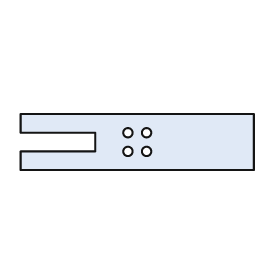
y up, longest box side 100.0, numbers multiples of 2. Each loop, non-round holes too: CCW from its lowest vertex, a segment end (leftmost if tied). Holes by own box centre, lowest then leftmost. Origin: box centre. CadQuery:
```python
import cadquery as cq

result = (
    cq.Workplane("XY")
    .moveTo(-50.0, -12.0)
    .lineTo(50.0, -12.0)
    .lineTo(50.0, 12.0)
    .lineTo(-50.0, 12.0)
    .lineTo(-50.0, 4.0)
    .lineTo(-18.0, 4.0)
    .lineTo(-18.0, -4.0)
    .lineTo(-50.0, -4.0)
    .close()
    .moveTo(-4.0, -4.0)
    .circle(2.0)
    .moveTo(4.0, -4.0)
    .circle(2.0)
    .moveTo(-4.0, 4.0)
    .circle(2.0)
    .moveTo(4.0, 4.0)
    .circle(2.0)
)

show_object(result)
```